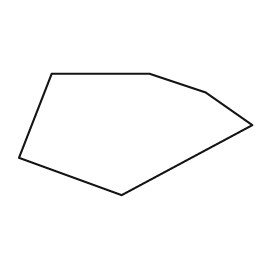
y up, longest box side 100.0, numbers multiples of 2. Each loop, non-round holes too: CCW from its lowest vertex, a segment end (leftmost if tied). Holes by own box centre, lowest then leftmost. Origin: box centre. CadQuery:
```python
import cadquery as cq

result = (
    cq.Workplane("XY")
    .moveTo(-6.0, -26.0)
    .lineTo(50.0, 4.0)
    .lineTo(30.0, 18.0)
    .lineTo(6.0, 26.0)
    .lineTo(-36.0, 26.0)
    .lineTo(-50.0, -10.0)
    .close()
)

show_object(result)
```